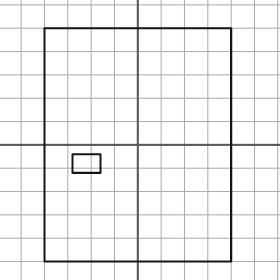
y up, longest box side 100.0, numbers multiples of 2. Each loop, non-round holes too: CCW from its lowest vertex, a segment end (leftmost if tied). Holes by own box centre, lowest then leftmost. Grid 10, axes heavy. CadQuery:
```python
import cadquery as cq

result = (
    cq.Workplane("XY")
    .moveTo(-40.0, -50.0)
    .lineTo(40.0, -50.0)
    .lineTo(40.0, 50.0)
    .lineTo(-40.0, 50.0)
    .close()
    .moveTo(-28.0, -12.0)
    .lineTo(-16.0, -12.0)
    .lineTo(-16.0, -4.0)
    .lineTo(-28.0, -4.0)
    .close()
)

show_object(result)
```